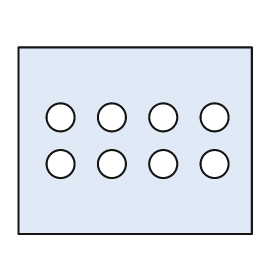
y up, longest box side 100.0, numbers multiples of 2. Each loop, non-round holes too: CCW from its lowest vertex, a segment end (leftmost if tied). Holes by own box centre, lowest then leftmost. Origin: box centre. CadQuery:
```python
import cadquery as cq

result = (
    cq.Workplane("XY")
    .moveTo(-50.0, -40.0)
    .lineTo(50.0, -40.0)
    .lineTo(50.0, 40.0)
    .lineTo(-50.0, 40.0)
    .close()
    .moveTo(-32.0, -10.0)
    .circle(6.0)
    .moveTo(-10.0, -10.0)
    .circle(6.0)
    .moveTo(12.0, -10.0)
    .circle(6.0)
    .moveTo(34.0, -10.0)
    .circle(6.0)
    .moveTo(-32.0, 10.0)
    .circle(6.0)
    .moveTo(-10.0, 10.0)
    .circle(6.0)
    .moveTo(12.0, 10.0)
    .circle(6.0)
    .moveTo(34.0, 10.0)
    .circle(6.0)
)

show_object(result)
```